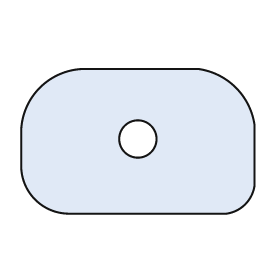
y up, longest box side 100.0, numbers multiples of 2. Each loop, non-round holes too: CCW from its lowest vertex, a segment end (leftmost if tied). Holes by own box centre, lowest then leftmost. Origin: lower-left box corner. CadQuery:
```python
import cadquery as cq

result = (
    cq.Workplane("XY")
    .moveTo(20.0, 0.0)
    .lineTo(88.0, 0.0)
    .threePointArc((96.0, 4.0), (100.0, 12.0))
    .lineTo(100.0, 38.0)
    .threePointArc((92.0, 54.0), (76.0, 62.0))
    .lineTo(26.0, 62.0)
    .threePointArc((8.0, 54.0), (0.0, 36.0))
    .lineTo(0.0, 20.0)
    .threePointArc((6.0, 6.0), (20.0, 0.0))
    .close()
    .moveTo(50.0, 32.0)
    .circle(8.0)
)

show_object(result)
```